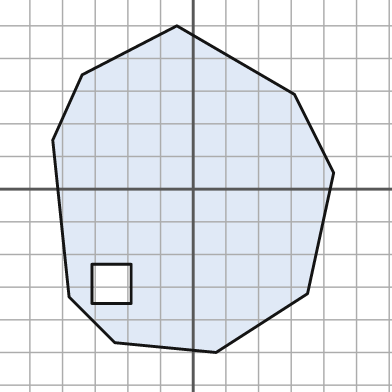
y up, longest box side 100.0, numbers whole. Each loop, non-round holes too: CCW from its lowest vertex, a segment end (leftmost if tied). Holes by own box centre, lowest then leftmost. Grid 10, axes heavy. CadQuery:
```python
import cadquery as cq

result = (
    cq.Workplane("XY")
    .moveTo(7.0, -50.0)
    .lineTo(35.0, -32.0)
    .lineTo(43.0, 5.0)
    .lineTo(31.0, 29.0)
    .lineTo(-5.0, 50.0)
    .lineTo(-34.0, 35.0)
    .lineTo(-43.0, 15.0)
    .lineTo(-38.0, -33.0)
    .lineTo(-24.0, -47.0)
    .close()
    .moveTo(-31.0, -35.0)
    .lineTo(-19.0, -35.0)
    .lineTo(-19.0, -23.0)
    .lineTo(-31.0, -23.0)
    .close()
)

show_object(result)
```